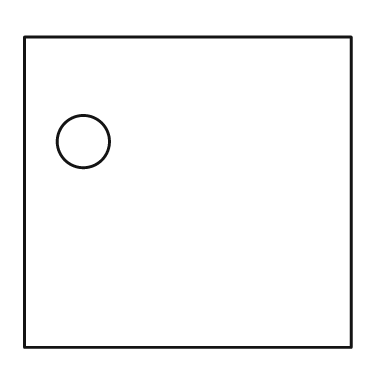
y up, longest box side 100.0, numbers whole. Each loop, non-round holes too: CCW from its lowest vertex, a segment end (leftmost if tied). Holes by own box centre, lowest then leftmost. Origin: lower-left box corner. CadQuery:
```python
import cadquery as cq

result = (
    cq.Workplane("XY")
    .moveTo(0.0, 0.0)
    .lineTo(100.0, 0.0)
    .lineTo(100.0, 95.0)
    .lineTo(0.0, 95.0)
    .close()
    .moveTo(18.0, 63.0)
    .circle(8.0)
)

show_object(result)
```